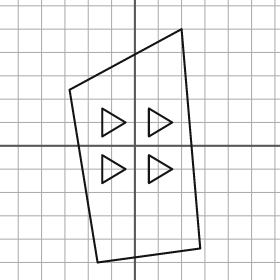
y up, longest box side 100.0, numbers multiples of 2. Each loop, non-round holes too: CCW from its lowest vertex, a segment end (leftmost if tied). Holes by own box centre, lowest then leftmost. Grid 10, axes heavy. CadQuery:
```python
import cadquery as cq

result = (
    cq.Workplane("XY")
    .moveTo(-16.0, -50.0)
    .lineTo(28.0, -44.0)
    .lineTo(20.0, 50.0)
    .lineTo(-28.0, 24.0)
    .close()
    .moveTo(-14.0, -16.0)
    .lineTo(-4.0, -10.0)
    .lineTo(-14.0, -4.0)
    .close()
    .moveTo(6.0, -16.0)
    .lineTo(16.0, -10.0)
    .lineTo(6.0, -4.0)
    .close()
    .moveTo(-14.0, 4.0)
    .lineTo(-4.0, 10.0)
    .lineTo(-14.0, 16.0)
    .close()
    .moveTo(6.0, 4.0)
    .lineTo(16.0, 10.0)
    .lineTo(6.0, 16.0)
    .close()
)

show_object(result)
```